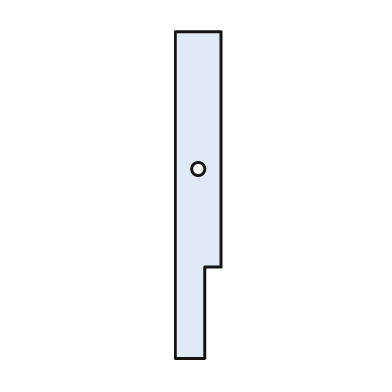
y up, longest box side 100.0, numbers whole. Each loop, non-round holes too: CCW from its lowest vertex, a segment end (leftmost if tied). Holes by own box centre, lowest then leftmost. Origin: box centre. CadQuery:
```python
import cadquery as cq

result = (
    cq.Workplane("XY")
    .moveTo(-7.0, -50.0)
    .lineTo(2.0, -50.0)
    .lineTo(2.0, -22.0)
    .lineTo(7.0, -22.0)
    .lineTo(7.0, 50.0)
    .lineTo(-7.0, 50.0)
    .close()
    .moveTo(0.0, 8.0)
    .circle(2.0)
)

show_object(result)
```